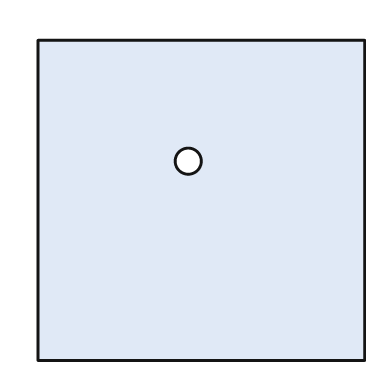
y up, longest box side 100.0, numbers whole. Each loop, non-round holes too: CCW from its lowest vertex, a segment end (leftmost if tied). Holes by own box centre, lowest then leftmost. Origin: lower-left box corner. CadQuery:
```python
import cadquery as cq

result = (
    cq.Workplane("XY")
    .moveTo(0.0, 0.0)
    .lineTo(100.0, 0.0)
    .lineTo(100.0, 98.0)
    .lineTo(0.0, 98.0)
    .close()
    .moveTo(46.0, 61.0)
    .circle(4.0)
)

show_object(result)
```